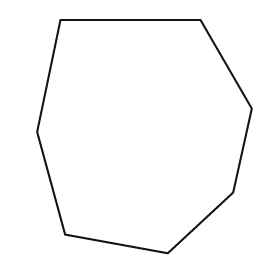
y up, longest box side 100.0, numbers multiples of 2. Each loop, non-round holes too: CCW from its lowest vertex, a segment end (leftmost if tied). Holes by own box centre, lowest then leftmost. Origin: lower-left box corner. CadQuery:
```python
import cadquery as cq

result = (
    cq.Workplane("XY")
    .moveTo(56.0, 0.0)
    .lineTo(84.0, 26.0)
    .lineTo(92.0, 62.0)
    .lineTo(70.0, 100.0)
    .lineTo(10.0, 100.0)
    .lineTo(0.0, 52.0)
    .lineTo(12.0, 8.0)
    .close()
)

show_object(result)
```